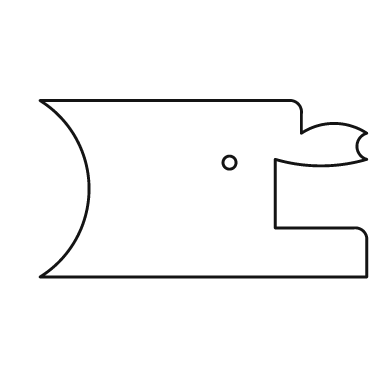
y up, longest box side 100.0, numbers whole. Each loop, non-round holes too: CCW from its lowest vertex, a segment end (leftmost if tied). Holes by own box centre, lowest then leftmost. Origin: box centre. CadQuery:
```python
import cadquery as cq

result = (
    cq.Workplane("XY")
    .moveTo(-50.0, -27.0)
    .lineTo(50.0, -27.0)
    .lineTo(50.0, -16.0)
    .threePointArc((49.0, -13.0), (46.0, -12.0))
    .lineTo(22.0, -12.0)
    .lineTo(22.0, 9.0)
    .threePointArc((36.0, 7.0), (50.0, 9.0))
    .threePointArc((47.0, 13.0), (50.0, 17.0))
    .threePointArc((40.0, 20.0), (30.0, 17.0))
    .lineTo(30.0, 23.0)
    .threePointArc((29.0, 26.0), (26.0, 27.0))
    .lineTo(-50.0, 27.0)
    .threePointArc((-35.0, 0.0), (-50.0, -27.0))
    .close()
    .moveTo(8.0, 8.0)
    .circle(2.0)
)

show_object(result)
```